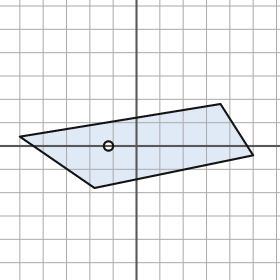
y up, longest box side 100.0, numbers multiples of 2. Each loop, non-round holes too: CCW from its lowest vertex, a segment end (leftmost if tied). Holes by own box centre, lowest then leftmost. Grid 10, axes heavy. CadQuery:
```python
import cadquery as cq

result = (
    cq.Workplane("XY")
    .moveTo(-18.0, -18.0)
    .lineTo(50.0, -4.0)
    .lineTo(36.0, 18.0)
    .lineTo(-50.0, 4.0)
    .close()
    .moveTo(-12.0, 0.0)
    .circle(2.0)
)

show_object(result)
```